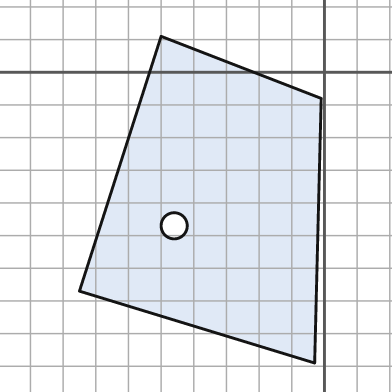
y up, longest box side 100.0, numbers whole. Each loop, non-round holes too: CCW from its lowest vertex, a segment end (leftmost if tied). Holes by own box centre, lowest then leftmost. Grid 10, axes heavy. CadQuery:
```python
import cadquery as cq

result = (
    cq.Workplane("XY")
    .moveTo(-3.0, -89.0)
    .lineTo(-1.0, -8.0)
    .lineTo(-50.0, 11.0)
    .lineTo(-75.0, -67.0)
    .close()
    .moveTo(-46.0, -47.0)
    .circle(4.0)
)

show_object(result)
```